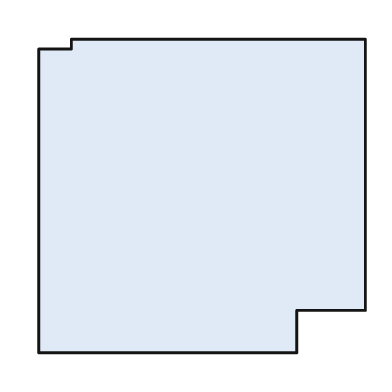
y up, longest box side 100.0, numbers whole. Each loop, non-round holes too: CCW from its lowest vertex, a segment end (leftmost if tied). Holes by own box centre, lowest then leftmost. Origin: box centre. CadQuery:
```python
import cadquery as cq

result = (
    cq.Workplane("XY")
    .moveTo(-50.0, -48.0)
    .lineTo(29.0, -48.0)
    .lineTo(29.0, -35.0)
    .lineTo(50.0, -35.0)
    .lineTo(50.0, 48.0)
    .lineTo(-40.0, 48.0)
    .lineTo(-40.0, 45.0)
    .lineTo(-50.0, 45.0)
    .close()
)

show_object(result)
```